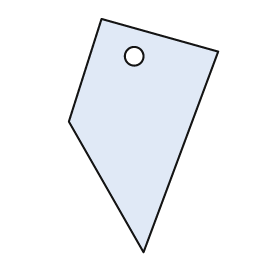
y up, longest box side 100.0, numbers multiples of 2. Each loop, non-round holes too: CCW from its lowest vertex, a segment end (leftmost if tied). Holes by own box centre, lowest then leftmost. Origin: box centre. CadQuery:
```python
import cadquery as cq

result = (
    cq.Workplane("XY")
    .moveTo(0.0, -50.0)
    .lineTo(32.0, 36.0)
    .lineTo(-18.0, 50.0)
    .lineTo(-32.0, 6.0)
    .close()
    .moveTo(-4.0, 34.0)
    .circle(4.0)
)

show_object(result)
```